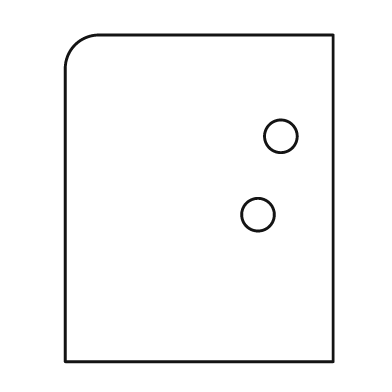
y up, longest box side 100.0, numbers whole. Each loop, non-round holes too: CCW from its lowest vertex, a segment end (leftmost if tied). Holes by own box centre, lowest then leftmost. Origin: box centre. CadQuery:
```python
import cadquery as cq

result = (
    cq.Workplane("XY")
    .moveTo(-41.0, -50.0)
    .lineTo(41.0, -50.0)
    .lineTo(41.0, 50.0)
    .lineTo(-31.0, 50.0)
    .threePointArc((-38.0, 47.0), (-41.0, 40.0))
    .close()
    .moveTo(18.0, -5.0)
    .circle(5.0)
    .moveTo(25.0, 19.0)
    .circle(5.0)
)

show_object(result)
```